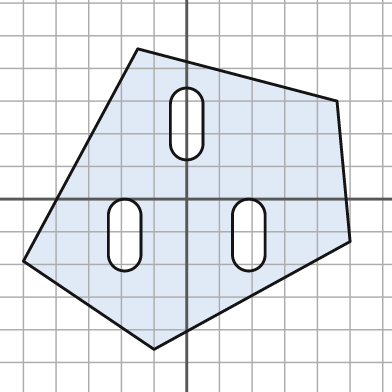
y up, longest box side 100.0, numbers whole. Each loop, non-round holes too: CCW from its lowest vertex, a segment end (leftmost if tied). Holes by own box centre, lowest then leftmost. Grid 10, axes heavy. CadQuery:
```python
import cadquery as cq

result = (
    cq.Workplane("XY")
    .moveTo(-10.0, -46.0)
    .lineTo(50.0, -13.0)
    .lineTo(46.0, 30.0)
    .lineTo(-15.0, 46.0)
    .lineTo(-50.0, -19.0)
    .close()
    .moveTo(-24.0, -17.0)
    .threePointArc((-19.0, -22.0), (-14.0, -17.0))
    .lineTo(-14.0, -5.0)
    .threePointArc((-19.0, 0.0), (-24.0, -5.0))
    .close()
    .moveTo(14.0, -17.0)
    .threePointArc((19.0, -22.0), (24.0, -17.0))
    .lineTo(24.0, -5.0)
    .threePointArc((19.0, 0.0), (14.0, -5.0))
    .close()
    .moveTo(-5.0, 17.0)
    .threePointArc((0.0, 12.0), (5.0, 17.0))
    .lineTo(5.0, 29.0)
    .threePointArc((0.0, 34.0), (-5.0, 29.0))
    .close()
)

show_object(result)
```